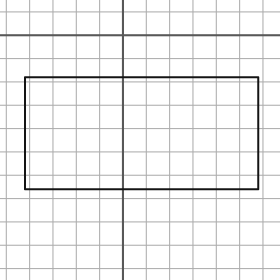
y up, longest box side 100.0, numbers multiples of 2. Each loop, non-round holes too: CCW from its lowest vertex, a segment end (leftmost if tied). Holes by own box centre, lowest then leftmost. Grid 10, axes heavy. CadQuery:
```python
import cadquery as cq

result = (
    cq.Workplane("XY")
    .moveTo(-42.0, -66.0)
    .lineTo(58.0, -66.0)
    .lineTo(58.0, -18.0)
    .lineTo(-42.0, -18.0)
    .close()
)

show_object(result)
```